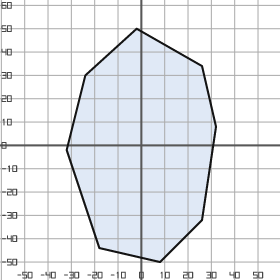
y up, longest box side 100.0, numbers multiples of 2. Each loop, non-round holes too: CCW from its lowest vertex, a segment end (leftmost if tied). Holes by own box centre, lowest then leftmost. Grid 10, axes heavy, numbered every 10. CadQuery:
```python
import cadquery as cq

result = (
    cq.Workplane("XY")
    .moveTo(8.0, -50.0)
    .lineTo(26.0, -32.0)
    .lineTo(32.0, 8.0)
    .lineTo(26.0, 34.0)
    .lineTo(-2.0, 50.0)
    .lineTo(-24.0, 30.0)
    .lineTo(-32.0, -2.0)
    .lineTo(-18.0, -44.0)
    .close()
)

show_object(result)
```